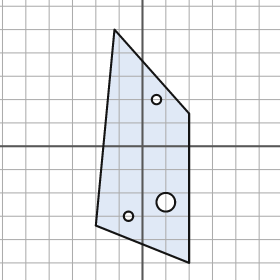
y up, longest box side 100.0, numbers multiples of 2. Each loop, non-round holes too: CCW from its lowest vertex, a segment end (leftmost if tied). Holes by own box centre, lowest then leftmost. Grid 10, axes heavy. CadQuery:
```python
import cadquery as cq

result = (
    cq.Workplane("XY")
    .moveTo(20.0, -50.0)
    .lineTo(20.0, 14.0)
    .lineTo(-12.0, 50.0)
    .lineTo(-20.0, -34.0)
    .close()
    .moveTo(-6.0, -30.0)
    .circle(2.0)
    .moveTo(10.0, -24.0)
    .circle(4.0)
    .moveTo(6.0, 20.0)
    .circle(2.0)
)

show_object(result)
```